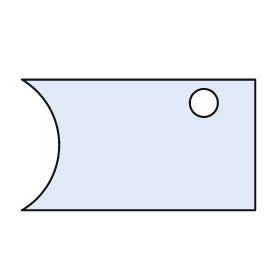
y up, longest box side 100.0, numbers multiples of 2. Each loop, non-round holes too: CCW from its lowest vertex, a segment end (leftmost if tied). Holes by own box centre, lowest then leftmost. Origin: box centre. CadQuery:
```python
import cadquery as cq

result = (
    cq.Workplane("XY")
    .moveTo(-50.0, -28.0)
    .lineTo(50.0, -28.0)
    .lineTo(50.0, 28.0)
    .lineTo(-50.0, 28.0)
    .threePointArc((-34.0, 0.0), (-50.0, -28.0))
    .close()
    .moveTo(28.0, 18.0)
    .circle(6.0)
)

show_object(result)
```